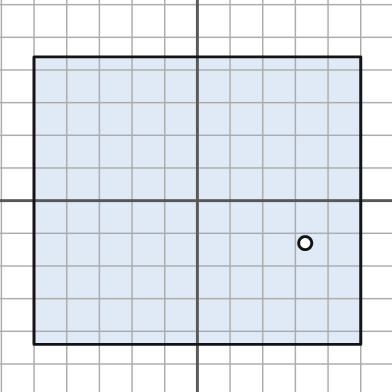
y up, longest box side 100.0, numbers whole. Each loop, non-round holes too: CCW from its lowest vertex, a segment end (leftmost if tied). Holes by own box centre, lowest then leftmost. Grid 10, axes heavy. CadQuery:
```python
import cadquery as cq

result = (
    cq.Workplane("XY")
    .moveTo(-50.0, -44.0)
    .lineTo(50.0, -44.0)
    .lineTo(50.0, 44.0)
    .lineTo(-50.0, 44.0)
    .close()
    .moveTo(33.0, -13.0)
    .circle(2.0)
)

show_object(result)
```